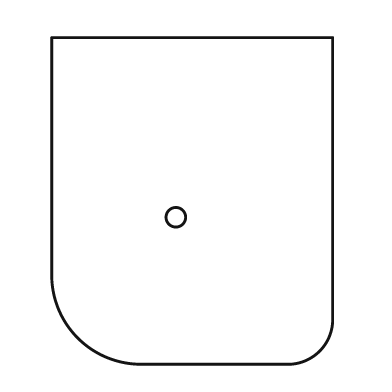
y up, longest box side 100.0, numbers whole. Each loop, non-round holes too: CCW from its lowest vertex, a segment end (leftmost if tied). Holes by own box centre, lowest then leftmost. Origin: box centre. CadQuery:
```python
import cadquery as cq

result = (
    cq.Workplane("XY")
    .moveTo(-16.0, -50.0)
    .lineTo(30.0, -50.0)
    .threePointArc((39.0, -46.0), (43.0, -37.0))
    .lineTo(43.0, 50.0)
    .lineTo(-43.0, 50.0)
    .lineTo(-43.0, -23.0)
    .threePointArc((-35.0, -42.0), (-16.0, -50.0))
    .close()
    .moveTo(-5.0, -5.0)
    .circle(3.0)
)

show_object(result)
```